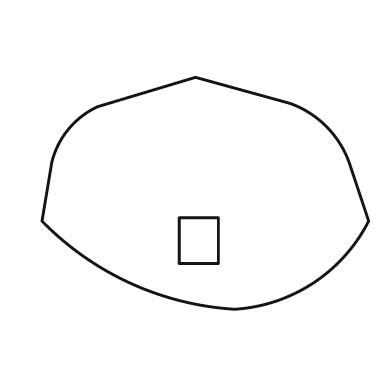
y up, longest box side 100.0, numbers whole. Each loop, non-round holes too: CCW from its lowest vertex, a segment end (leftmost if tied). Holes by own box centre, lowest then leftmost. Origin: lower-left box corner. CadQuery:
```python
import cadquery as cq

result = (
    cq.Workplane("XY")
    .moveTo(59.0, 0.0)
    .threePointArc((83.0, 8.0), (100.0, 27.0))
    .lineTo(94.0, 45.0)
    .threePointArc((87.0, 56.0), (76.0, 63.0))
    .lineTo(47.0, 71.0)
    .lineTo(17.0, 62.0)
    .threePointArc((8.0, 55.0), (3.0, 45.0))
    .lineTo(0.0, 27.0)
    .threePointArc((27.0, 8.0), (59.0, 0.0))
    .close()
    .moveTo(42.0, 14.0)
    .lineTo(54.0, 14.0)
    .lineTo(54.0, 28.0)
    .lineTo(42.0, 28.0)
    .close()
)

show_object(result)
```